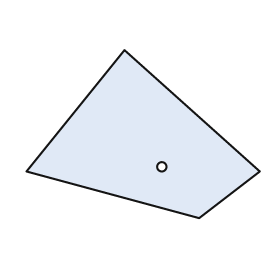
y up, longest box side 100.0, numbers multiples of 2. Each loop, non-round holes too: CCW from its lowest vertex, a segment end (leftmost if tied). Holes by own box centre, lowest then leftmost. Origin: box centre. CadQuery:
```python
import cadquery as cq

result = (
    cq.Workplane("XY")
    .moveTo(24.0, -36.0)
    .lineTo(50.0, -16.0)
    .lineTo(-8.0, 36.0)
    .lineTo(-50.0, -16.0)
    .close()
    .moveTo(8.0, -14.0)
    .circle(2.0)
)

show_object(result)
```